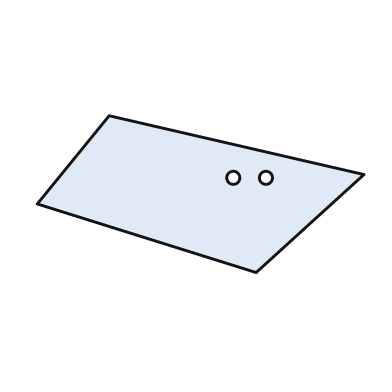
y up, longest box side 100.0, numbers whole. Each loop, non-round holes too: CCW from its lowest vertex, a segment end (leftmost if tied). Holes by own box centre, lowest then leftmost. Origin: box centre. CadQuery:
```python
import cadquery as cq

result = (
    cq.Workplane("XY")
    .moveTo(17.0, -24.0)
    .lineTo(50.0, 6.0)
    .lineTo(-28.0, 24.0)
    .lineTo(-50.0, -3.0)
    .close()
    .moveTo(10.0, 5.0)
    .circle(2.0)
    .moveTo(20.0, 5.0)
    .circle(2.0)
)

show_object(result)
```